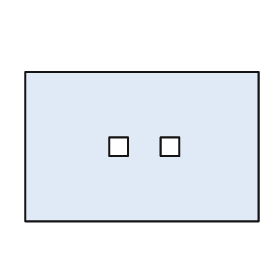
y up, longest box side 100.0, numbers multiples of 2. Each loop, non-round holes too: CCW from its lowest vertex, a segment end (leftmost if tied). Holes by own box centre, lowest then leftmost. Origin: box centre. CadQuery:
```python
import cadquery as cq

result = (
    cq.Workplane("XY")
    .moveTo(-50.0, -32.0)
    .lineTo(50.0, -32.0)
    .lineTo(50.0, 32.0)
    .lineTo(-50.0, 32.0)
    .close()
    .moveTo(-14.0, -4.0)
    .lineTo(-6.0, -4.0)
    .lineTo(-6.0, 4.0)
    .lineTo(-14.0, 4.0)
    .close()
    .moveTo(8.0, -4.0)
    .lineTo(16.0, -4.0)
    .lineTo(16.0, 4.0)
    .lineTo(8.0, 4.0)
    .close()
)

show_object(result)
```